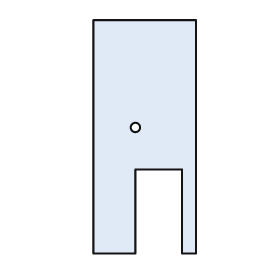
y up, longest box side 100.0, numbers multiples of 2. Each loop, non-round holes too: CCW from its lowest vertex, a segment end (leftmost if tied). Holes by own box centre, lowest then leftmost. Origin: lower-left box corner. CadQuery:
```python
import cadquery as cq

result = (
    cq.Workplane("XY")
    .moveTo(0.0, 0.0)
    .lineTo(18.0, 0.0)
    .lineTo(18.0, 36.0)
    .lineTo(38.0, 36.0)
    .lineTo(38.0, 0.0)
    .lineTo(44.0, 0.0)
    .lineTo(44.0, 100.0)
    .lineTo(0.0, 100.0)
    .close()
    .moveTo(18.0, 54.0)
    .circle(2.0)
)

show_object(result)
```